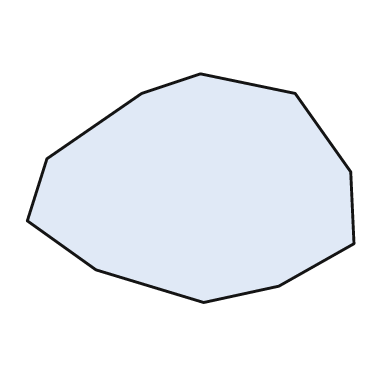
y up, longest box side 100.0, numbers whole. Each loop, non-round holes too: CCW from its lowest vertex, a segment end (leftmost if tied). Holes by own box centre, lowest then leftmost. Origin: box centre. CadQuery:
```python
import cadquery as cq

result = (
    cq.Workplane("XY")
    .moveTo(4.0, -35.0)
    .lineTo(27.0, -30.0)
    .lineTo(50.0, -17.0)
    .lineTo(49.0, 5.0)
    .lineTo(32.0, 29.0)
    .lineTo(3.0, 35.0)
    .lineTo(-15.0, 29.0)
    .lineTo(-44.0, 9.0)
    .lineTo(-50.0, -10.0)
    .lineTo(-29.0, -25.0)
    .close()
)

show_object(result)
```